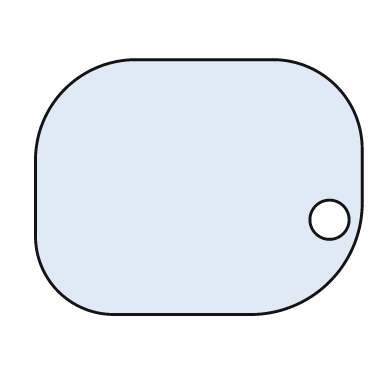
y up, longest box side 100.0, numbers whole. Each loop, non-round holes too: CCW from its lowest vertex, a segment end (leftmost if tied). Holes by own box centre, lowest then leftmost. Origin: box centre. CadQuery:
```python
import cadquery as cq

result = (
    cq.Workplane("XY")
    .moveTo(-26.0, -39.0)
    .lineTo(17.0, -39.0)
    .threePointArc((40.0, -29.0), (50.0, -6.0))
    .lineTo(50.0, 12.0)
    .threePointArc((42.0, 31.0), (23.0, 39.0))
    .lineTo(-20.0, 39.0)
    .threePointArc((-41.0, 30.0), (-50.0, 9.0))
    .lineTo(-50.0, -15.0)
    .threePointArc((-43.0, -32.0), (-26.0, -39.0))
    .close()
    .moveTo(40.0, -10.0)
    .circle(6.0)
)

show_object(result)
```